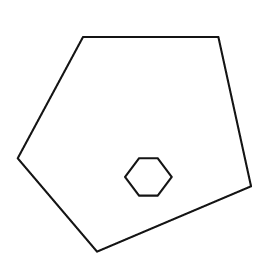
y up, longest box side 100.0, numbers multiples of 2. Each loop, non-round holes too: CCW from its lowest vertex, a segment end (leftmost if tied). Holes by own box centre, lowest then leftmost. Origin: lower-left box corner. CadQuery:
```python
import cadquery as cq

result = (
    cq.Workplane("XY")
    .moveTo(34.0, 0.0)
    .lineTo(100.0, 28.0)
    .lineTo(86.0, 92.0)
    .lineTo(28.0, 92.0)
    .lineTo(0.0, 40.0)
    .close()
    .moveTo(52.0, 24.0)
    .lineTo(60.0, 24.0)
    .lineTo(66.0, 32.0)
    .lineTo(60.0, 40.0)
    .lineTo(52.0, 40.0)
    .lineTo(46.0, 32.0)
    .close()
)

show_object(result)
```